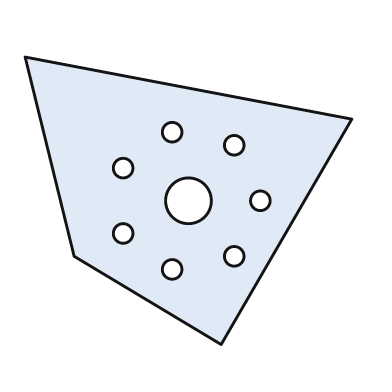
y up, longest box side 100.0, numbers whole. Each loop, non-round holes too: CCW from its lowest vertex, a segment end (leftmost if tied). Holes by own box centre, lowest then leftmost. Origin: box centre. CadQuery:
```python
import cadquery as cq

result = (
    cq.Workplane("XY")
    .moveTo(10.0, -44.0)
    .lineTo(50.0, 25.0)
    .lineTo(-50.0, 44.0)
    .lineTo(-35.0, -17.0)
    .close()
    .moveTo(-5.0, -21.0)
    .circle(3.0)
    .moveTo(14.0, -17.0)
    .circle(3.0)
    .moveTo(-20.0, -10.0)
    .circle(3.0)
    .moveTo(0.0, 0.0)
    .circle(7.0)
    .moveTo(22.0, 0.0)
    .circle(3.0)
    .moveTo(-20.0, 10.0)
    .circle(3.0)
    .moveTo(14.0, 17.0)
    .circle(3.0)
    .moveTo(-5.0, 21.0)
    .circle(3.0)
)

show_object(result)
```